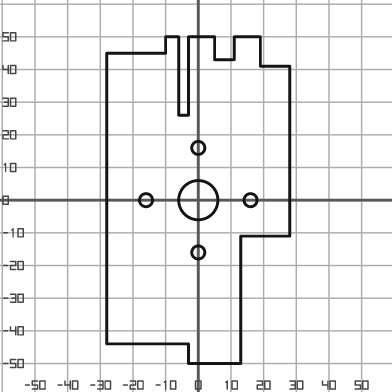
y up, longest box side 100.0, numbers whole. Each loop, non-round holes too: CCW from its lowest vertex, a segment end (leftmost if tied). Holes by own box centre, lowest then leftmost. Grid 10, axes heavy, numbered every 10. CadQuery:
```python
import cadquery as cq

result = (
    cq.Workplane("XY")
    .moveTo(-3.0, -50.0)
    .lineTo(13.0, -50.0)
    .lineTo(13.0, -11.0)
    .lineTo(28.0, -11.0)
    .lineTo(28.0, 41.0)
    .lineTo(19.0, 41.0)
    .lineTo(19.0, 50.0)
    .lineTo(11.0, 50.0)
    .lineTo(11.0, 43.0)
    .lineTo(5.0, 43.0)
    .lineTo(5.0, 50.0)
    .lineTo(-3.0, 50.0)
    .lineTo(-3.0, 26.0)
    .lineTo(-6.0, 26.0)
    .lineTo(-6.0, 50.0)
    .lineTo(-10.0, 50.0)
    .lineTo(-10.0, 45.0)
    .lineTo(-28.0, 45.0)
    .lineTo(-28.0, -44.0)
    .lineTo(-3.0, -44.0)
    .close()
    .moveTo(0.0, -16.0)
    .circle(2.0)
    .moveTo(-16.0, 0.0)
    .circle(2.0)
    .moveTo(0.0, 0.0)
    .circle(6.0)
    .moveTo(16.0, 0.0)
    .circle(2.0)
    .moveTo(0.0, 16.0)
    .circle(2.0)
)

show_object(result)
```